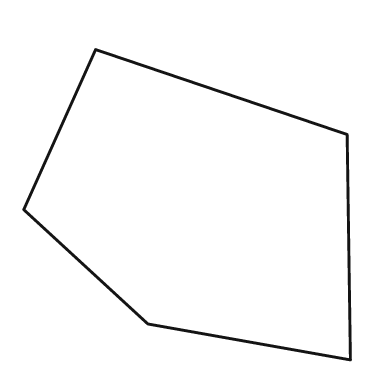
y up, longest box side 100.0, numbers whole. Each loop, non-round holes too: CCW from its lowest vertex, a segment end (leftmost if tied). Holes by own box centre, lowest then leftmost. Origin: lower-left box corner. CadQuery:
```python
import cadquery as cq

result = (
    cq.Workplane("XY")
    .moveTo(100.0, 0.0)
    .lineTo(99.0, 69.0)
    .lineTo(22.0, 95.0)
    .lineTo(0.0, 46.0)
    .lineTo(38.0, 11.0)
    .close()
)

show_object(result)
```